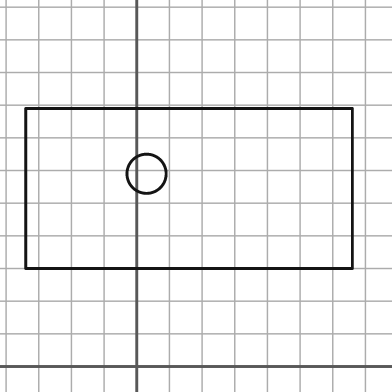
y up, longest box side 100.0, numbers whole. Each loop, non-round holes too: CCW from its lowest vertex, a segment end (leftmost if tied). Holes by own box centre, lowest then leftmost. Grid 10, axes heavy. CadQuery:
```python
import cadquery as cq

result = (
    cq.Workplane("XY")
    .moveTo(-34.0, 30.0)
    .lineTo(66.0, 30.0)
    .lineTo(66.0, 79.0)
    .lineTo(-34.0, 79.0)
    .close()
    .moveTo(3.0, 59.0)
    .circle(6.0)
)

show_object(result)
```